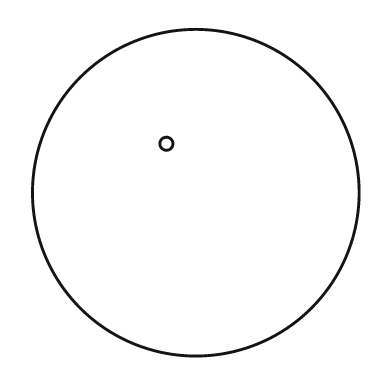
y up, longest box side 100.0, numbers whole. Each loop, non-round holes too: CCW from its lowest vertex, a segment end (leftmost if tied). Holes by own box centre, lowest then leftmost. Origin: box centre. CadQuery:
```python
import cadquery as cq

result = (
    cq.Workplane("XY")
    .moveTo(0.0, 0.0)
    .circle(50.0)
    .moveTo(-9.0, 15.0)
    .circle(2.0)
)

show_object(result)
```